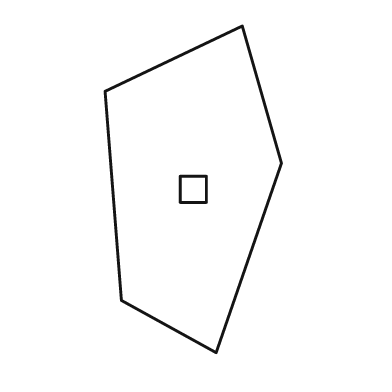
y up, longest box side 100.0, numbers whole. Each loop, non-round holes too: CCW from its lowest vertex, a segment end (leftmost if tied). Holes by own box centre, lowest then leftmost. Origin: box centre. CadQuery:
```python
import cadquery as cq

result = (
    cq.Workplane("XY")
    .moveTo(7.0, -50.0)
    .lineTo(27.0, 8.0)
    .lineTo(15.0, 50.0)
    .lineTo(-27.0, 30.0)
    .lineTo(-22.0, -34.0)
    .close()
    .moveTo(-4.0, -4.0)
    .lineTo(4.0, -4.0)
    .lineTo(4.0, 4.0)
    .lineTo(-4.0, 4.0)
    .close()
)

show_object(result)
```